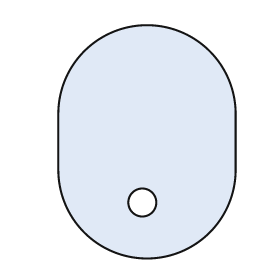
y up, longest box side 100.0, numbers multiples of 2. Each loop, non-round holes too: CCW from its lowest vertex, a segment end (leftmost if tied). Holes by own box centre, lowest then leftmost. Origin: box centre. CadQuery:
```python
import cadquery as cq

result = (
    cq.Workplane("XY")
    .moveTo(-38.0, -12.0)
    .threePointArc((0.0, -50.0), (38.0, -12.0))
    .lineTo(38.0, 12.0)
    .threePointArc((0.0, 50.0), (-38.0, 12.0))
    .close()
    .moveTo(-2.0, -26.0)
    .circle(6.0)
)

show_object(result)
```